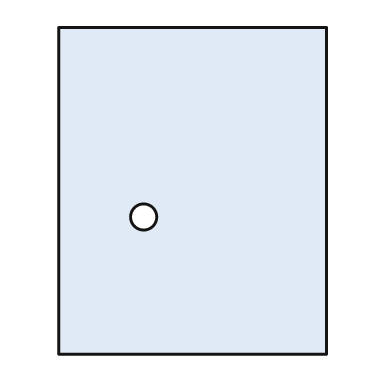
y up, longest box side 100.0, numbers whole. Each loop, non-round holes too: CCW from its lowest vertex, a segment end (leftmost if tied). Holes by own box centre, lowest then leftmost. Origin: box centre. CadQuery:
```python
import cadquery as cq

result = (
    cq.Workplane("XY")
    .moveTo(-41.0, -50.0)
    .lineTo(41.0, -50.0)
    .lineTo(41.0, 50.0)
    .lineTo(-41.0, 50.0)
    .close()
    .moveTo(-15.0, -8.0)
    .circle(4.0)
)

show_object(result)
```